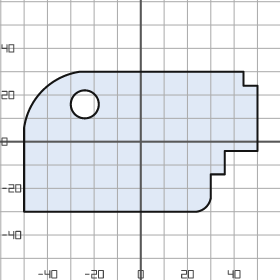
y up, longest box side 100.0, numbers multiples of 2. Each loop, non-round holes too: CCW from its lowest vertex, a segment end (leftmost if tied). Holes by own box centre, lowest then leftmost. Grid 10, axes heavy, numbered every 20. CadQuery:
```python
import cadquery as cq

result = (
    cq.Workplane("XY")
    .moveTo(-50.0, -30.0)
    .lineTo(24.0, -30.0)
    .threePointArc((28.0, -28.0), (30.0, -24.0))
    .lineTo(30.0, -14.0)
    .lineTo(36.0, -14.0)
    .lineTo(36.0, -4.0)
    .lineTo(50.0, -4.0)
    .lineTo(50.0, 24.0)
    .lineTo(44.0, 24.0)
    .lineTo(44.0, 30.0)
    .lineTo(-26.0, 30.0)
    .threePointArc((-42.0, 22.0), (-50.0, 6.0))
    .close()
    .moveTo(-24.0, 16.0)
    .circle(6.0)
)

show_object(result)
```